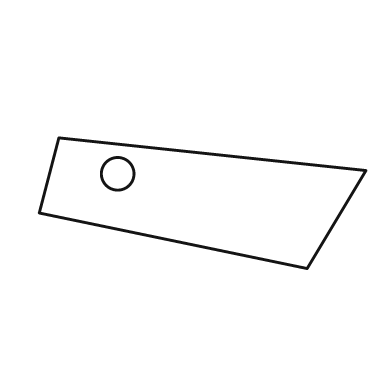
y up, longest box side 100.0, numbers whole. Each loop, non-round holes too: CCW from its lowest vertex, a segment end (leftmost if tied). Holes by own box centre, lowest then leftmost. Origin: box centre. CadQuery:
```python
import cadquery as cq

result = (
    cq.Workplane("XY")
    .moveTo(32.0, -20.0)
    .lineTo(50.0, 10.0)
    .lineTo(-44.0, 20.0)
    .lineTo(-50.0, -3.0)
    .close()
    .moveTo(-26.0, 9.0)
    .circle(5.0)
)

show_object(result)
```